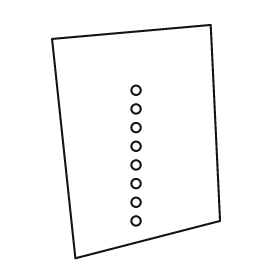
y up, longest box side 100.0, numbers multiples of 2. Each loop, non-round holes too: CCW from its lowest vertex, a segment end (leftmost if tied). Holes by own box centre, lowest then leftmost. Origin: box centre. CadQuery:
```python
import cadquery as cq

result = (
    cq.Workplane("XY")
    .moveTo(-26.0, -50.0)
    .lineTo(36.0, -34.0)
    .lineTo(32.0, 50.0)
    .lineTo(-36.0, 44.0)
    .close()
    .moveTo(0.0, -34.0)
    .circle(2.0)
    .moveTo(0.0, -26.0)
    .circle(2.0)
    .moveTo(0.0, -18.0)
    .circle(2.0)
    .moveTo(0.0, -10.0)
    .circle(2.0)
    .moveTo(0.0, -2.0)
    .circle(2.0)
    .moveTo(0.0, 6.0)
    .circle(2.0)
    .moveTo(0.0, 14.0)
    .circle(2.0)
    .moveTo(0.0, 22.0)
    .circle(2.0)
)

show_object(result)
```